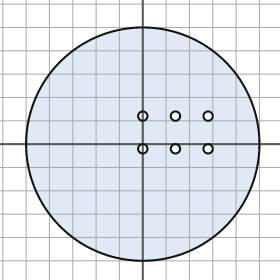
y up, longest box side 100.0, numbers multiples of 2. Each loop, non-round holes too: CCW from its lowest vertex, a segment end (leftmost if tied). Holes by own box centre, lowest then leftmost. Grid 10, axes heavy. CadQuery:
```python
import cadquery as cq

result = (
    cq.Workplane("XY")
    .moveTo(0.0, 0.0)
    .circle(50.0)
    .moveTo(0.0, -2.0)
    .circle(2.0)
    .moveTo(14.0, -2.0)
    .circle(2.0)
    .moveTo(28.0, -2.0)
    .circle(2.0)
    .moveTo(0.0, 12.0)
    .circle(2.0)
    .moveTo(14.0, 12.0)
    .circle(2.0)
    .moveTo(28.0, 12.0)
    .circle(2.0)
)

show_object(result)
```